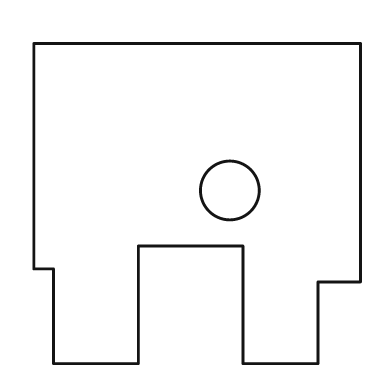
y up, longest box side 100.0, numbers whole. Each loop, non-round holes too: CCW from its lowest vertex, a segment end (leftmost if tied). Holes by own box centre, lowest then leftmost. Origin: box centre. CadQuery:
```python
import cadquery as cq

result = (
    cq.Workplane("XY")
    .moveTo(-44.0, -49.0)
    .lineTo(-18.0, -49.0)
    .lineTo(-18.0, -13.0)
    .lineTo(14.0, -13.0)
    .lineTo(14.0, -49.0)
    .lineTo(37.0, -49.0)
    .lineTo(37.0, -24.0)
    .lineTo(50.0, -24.0)
    .lineTo(50.0, 49.0)
    .lineTo(-50.0, 49.0)
    .lineTo(-50.0, -20.0)
    .lineTo(-44.0, -20.0)
    .close()
    .moveTo(10.0, 4.0)
    .circle(9.0)
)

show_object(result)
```